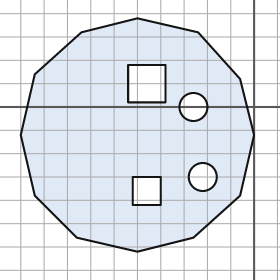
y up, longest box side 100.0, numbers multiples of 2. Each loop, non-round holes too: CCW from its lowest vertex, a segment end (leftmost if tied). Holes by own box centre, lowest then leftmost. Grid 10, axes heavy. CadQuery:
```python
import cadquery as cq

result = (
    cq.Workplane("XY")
    .moveTo(-50.0, -62.0)
    .lineTo(-26.0, -56.0)
    .lineTo(-6.0, -38.0)
    .lineTo(0.0, -12.0)
    .lineTo(-6.0, 12.0)
    .lineTo(-24.0, 32.0)
    .lineTo(-50.0, 38.0)
    .lineTo(-74.0, 32.0)
    .lineTo(-94.0, 14.0)
    .lineTo(-100.0, -12.0)
    .lineTo(-94.0, -38.0)
    .lineTo(-76.0, -56.0)
    .close()
    .moveTo(-52.0, -42.0)
    .lineTo(-40.0, -42.0)
    .lineTo(-40.0, -30.0)
    .lineTo(-52.0, -30.0)
    .close()
    .moveTo(-22.0, -30.0)
    .circle(6.0)
    .moveTo(-26.0, 0.0)
    .circle(6.0)
    .moveTo(-54.0, 2.0)
    .lineTo(-38.0, 2.0)
    .lineTo(-38.0, 18.0)
    .lineTo(-54.0, 18.0)
    .close()
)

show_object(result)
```